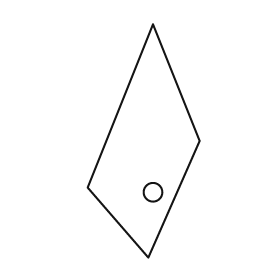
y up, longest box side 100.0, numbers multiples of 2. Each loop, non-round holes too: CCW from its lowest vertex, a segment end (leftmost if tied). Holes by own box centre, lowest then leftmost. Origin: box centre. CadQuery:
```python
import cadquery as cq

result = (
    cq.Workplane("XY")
    .moveTo(2.0, -50.0)
    .lineTo(24.0, 0.0)
    .lineTo(4.0, 50.0)
    .lineTo(-24.0, -20.0)
    .close()
    .moveTo(4.0, -22.0)
    .circle(4.0)
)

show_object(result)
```